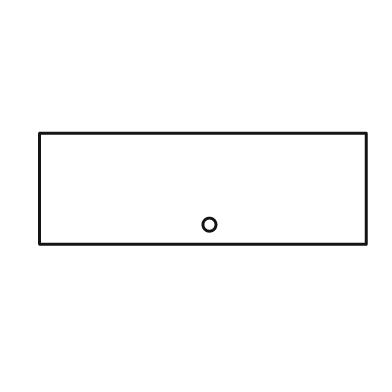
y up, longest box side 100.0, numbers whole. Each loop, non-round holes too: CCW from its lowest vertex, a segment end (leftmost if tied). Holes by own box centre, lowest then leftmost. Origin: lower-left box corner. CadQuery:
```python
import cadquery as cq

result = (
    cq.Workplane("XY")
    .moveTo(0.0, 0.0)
    .lineTo(100.0, 0.0)
    .lineTo(100.0, 34.0)
    .lineTo(0.0, 34.0)
    .close()
    .moveTo(52.0, 6.0)
    .circle(2.0)
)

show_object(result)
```